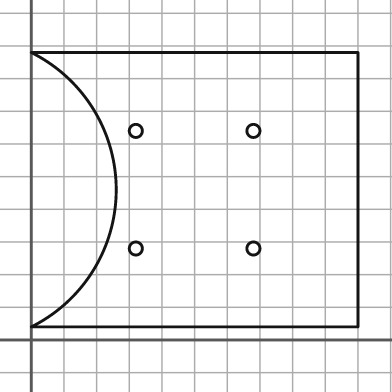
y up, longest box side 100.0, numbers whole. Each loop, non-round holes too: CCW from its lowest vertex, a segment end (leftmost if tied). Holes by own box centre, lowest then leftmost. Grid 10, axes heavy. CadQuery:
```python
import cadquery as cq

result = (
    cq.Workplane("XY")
    .moveTo(0.0, 4.0)
    .lineTo(100.0, 4.0)
    .lineTo(100.0, 88.0)
    .lineTo(0.0, 88.0)
    .threePointArc((26.0, 46.0), (0.0, 4.0))
    .close()
    .moveTo(32.0, 28.0)
    .circle(2.0)
    .moveTo(68.0, 28.0)
    .circle(2.0)
    .moveTo(32.0, 64.0)
    .circle(2.0)
    .moveTo(68.0, 64.0)
    .circle(2.0)
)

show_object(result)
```